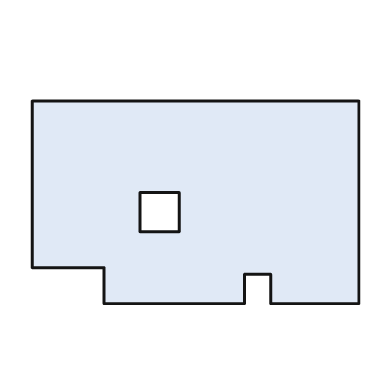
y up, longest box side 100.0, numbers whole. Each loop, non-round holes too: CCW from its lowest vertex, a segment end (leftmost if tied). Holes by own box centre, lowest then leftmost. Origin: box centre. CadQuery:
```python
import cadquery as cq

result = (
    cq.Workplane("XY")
    .moveTo(-28.0, -31.0)
    .lineTo(15.0, -31.0)
    .lineTo(15.0, -22.0)
    .lineTo(23.0, -22.0)
    .lineTo(23.0, -31.0)
    .lineTo(50.0, -31.0)
    .lineTo(50.0, 31.0)
    .lineTo(-50.0, 31.0)
    .lineTo(-50.0, -20.0)
    .lineTo(-28.0, -20.0)
    .close()
    .moveTo(-17.0, -9.0)
    .lineTo(-5.0, -9.0)
    .lineTo(-5.0, 3.0)
    .lineTo(-17.0, 3.0)
    .close()
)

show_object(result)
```